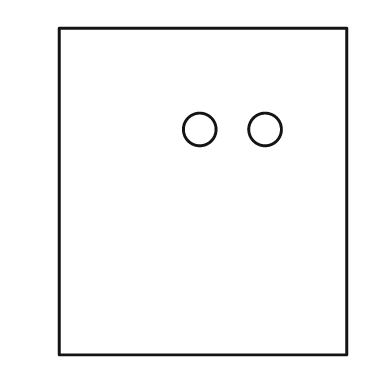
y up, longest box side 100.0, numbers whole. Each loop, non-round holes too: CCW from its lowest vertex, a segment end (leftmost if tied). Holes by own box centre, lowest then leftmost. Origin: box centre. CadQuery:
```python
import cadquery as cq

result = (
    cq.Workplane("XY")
    .moveTo(-44.0, -50.0)
    .lineTo(44.0, -50.0)
    .lineTo(44.0, 50.0)
    .lineTo(-44.0, 50.0)
    .close()
    .moveTo(-1.0, 19.0)
    .circle(5.0)
    .moveTo(19.0, 19.0)
    .circle(5.0)
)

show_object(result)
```